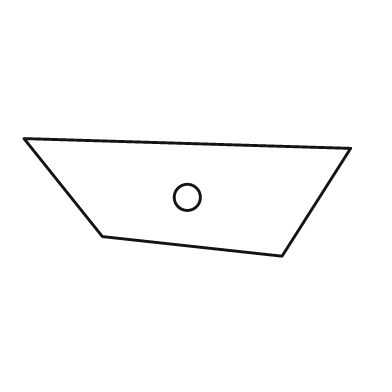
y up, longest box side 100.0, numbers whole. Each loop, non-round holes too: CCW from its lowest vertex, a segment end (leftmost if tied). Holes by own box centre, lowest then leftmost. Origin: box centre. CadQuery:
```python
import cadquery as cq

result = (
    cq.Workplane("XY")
    .moveTo(29.0, -18.0)
    .lineTo(50.0, 15.0)
    .lineTo(-50.0, 18.0)
    .lineTo(-26.0, -12.0)
    .close()
    .moveTo(0.0, 0.0)
    .circle(4.0)
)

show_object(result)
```